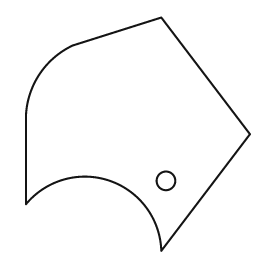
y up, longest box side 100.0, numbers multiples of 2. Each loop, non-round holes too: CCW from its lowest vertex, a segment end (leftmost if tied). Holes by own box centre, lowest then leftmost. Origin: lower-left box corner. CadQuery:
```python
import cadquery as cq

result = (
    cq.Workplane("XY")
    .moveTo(58.0, 0.0)
    .lineTo(96.0, 50.0)
    .lineTo(58.0, 100.0)
    .lineTo(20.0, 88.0)
    .threePointArc((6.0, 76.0), (0.0, 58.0))
    .lineTo(0.0, 20.0)
    .threePointArc((36.0, 30.0), (58.0, 0.0))
    .close()
    .moveTo(60.0, 30.0)
    .circle(4.0)
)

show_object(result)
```